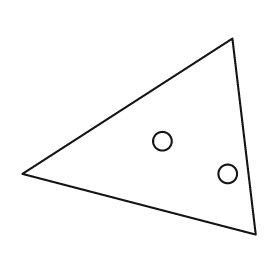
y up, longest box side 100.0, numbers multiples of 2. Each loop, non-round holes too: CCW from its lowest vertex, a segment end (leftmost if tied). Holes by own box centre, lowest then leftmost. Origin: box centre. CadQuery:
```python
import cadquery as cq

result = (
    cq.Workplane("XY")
    .moveTo(50.0, -42.0)
    .lineTo(40.0, 42.0)
    .lineTo(-50.0, -16.0)
    .close()
    .moveTo(38.0, -16.0)
    .circle(4.0)
    .moveTo(10.0, -2.0)
    .circle(4.0)
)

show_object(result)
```